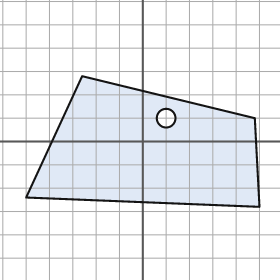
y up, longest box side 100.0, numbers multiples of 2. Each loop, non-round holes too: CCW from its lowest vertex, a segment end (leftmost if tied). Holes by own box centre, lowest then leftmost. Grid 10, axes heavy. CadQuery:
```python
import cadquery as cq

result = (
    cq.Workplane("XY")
    .moveTo(50.0, -28.0)
    .lineTo(48.0, 10.0)
    .lineTo(-26.0, 28.0)
    .lineTo(-50.0, -24.0)
    .close()
    .moveTo(10.0, 10.0)
    .circle(4.0)
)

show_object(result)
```